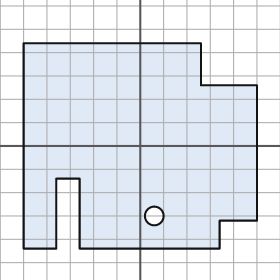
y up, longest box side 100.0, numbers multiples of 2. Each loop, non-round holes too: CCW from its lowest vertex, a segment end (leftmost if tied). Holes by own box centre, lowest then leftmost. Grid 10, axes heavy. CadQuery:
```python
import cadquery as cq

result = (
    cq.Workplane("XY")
    .moveTo(-50.0, -44.0)
    .lineTo(-36.0, -44.0)
    .lineTo(-36.0, -14.0)
    .lineTo(-26.0, -14.0)
    .lineTo(-26.0, -44.0)
    .lineTo(34.0, -44.0)
    .lineTo(34.0, -32.0)
    .lineTo(50.0, -32.0)
    .lineTo(50.0, 26.0)
    .lineTo(26.0, 26.0)
    .lineTo(26.0, 44.0)
    .lineTo(-50.0, 44.0)
    .close()
    .moveTo(6.0, -30.0)
    .circle(4.0)
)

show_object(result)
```